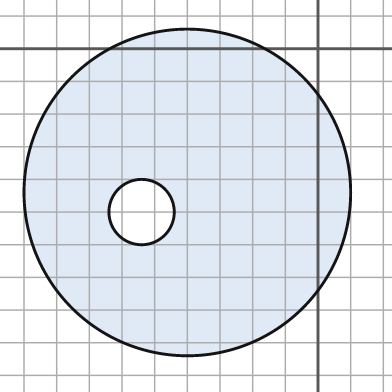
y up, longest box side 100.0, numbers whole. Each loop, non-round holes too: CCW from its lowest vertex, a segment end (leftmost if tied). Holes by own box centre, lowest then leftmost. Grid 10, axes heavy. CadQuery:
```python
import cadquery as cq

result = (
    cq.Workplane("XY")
    .moveTo(-40.0, -44.0)
    .circle(50.0)
    .moveTo(-54.0, -50.0)
    .circle(10.0)
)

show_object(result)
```